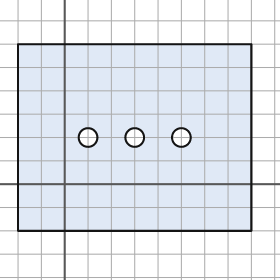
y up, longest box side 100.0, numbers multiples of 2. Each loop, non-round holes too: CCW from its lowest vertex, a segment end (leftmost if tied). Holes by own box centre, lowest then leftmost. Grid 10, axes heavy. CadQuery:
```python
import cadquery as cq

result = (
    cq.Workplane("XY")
    .moveTo(-20.0, -20.0)
    .lineTo(80.0, -20.0)
    .lineTo(80.0, 60.0)
    .lineTo(-20.0, 60.0)
    .close()
    .moveTo(10.0, 20.0)
    .circle(4.0)
    .moveTo(30.0, 20.0)
    .circle(4.0)
    .moveTo(50.0, 20.0)
    .circle(4.0)
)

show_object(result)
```